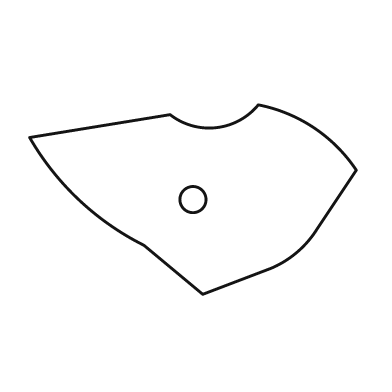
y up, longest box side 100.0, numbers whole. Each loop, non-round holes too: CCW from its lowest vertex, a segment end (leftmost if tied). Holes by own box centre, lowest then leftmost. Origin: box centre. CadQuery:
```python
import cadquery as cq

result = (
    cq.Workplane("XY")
    .moveTo(3.0, -29.0)
    .lineTo(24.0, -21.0)
    .threePointArc((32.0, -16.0), (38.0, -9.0))
    .lineTo(50.0, 9.0)
    .threePointArc((37.0, 22.0), (20.0, 29.0))
    .threePointArc((7.0, 22.0), (-7.0, 26.0))
    .lineTo(-50.0, 19.0)
    .threePointArc((-35.0, 0.0), (-15.0, -14.0))
    .close()
    .moveTo(0.0, 0.0)
    .circle(4.0)
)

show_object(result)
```